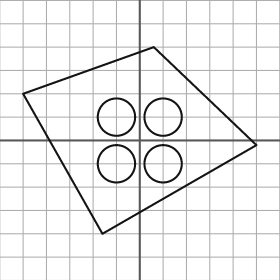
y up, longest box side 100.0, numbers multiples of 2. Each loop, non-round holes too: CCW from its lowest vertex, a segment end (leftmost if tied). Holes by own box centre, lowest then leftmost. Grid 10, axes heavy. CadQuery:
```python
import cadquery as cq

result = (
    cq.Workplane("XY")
    .moveTo(-16.0, -40.0)
    .lineTo(50.0, -2.0)
    .lineTo(6.0, 40.0)
    .lineTo(-50.0, 20.0)
    .close()
    .moveTo(-10.0, -10.0)
    .circle(8.0)
    .moveTo(10.0, -10.0)
    .circle(8.0)
    .moveTo(-10.0, 10.0)
    .circle(8.0)
    .moveTo(10.0, 10.0)
    .circle(8.0)
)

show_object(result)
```